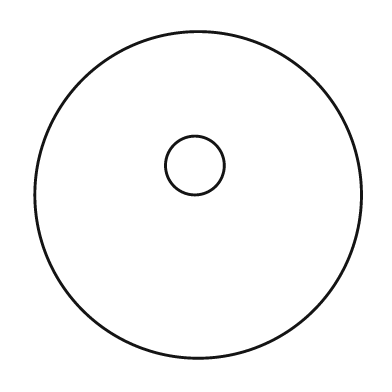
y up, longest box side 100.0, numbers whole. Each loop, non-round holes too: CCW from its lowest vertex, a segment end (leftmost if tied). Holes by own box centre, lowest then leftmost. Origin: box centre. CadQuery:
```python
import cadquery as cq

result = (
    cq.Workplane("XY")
    .moveTo(0.0, 0.0)
    .circle(50.0)
    .moveTo(-1.0, 9.0)
    .circle(9.0)
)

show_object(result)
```